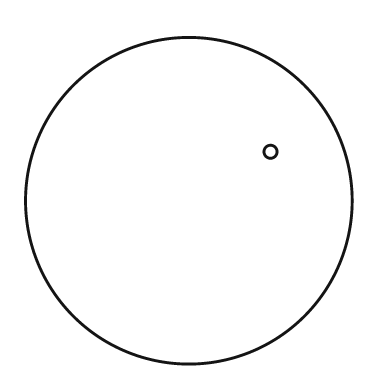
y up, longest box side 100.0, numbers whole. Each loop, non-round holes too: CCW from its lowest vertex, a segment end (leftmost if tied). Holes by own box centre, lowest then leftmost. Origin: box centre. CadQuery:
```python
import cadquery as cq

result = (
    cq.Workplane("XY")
    .moveTo(0.0, 0.0)
    .circle(50.0)
    .moveTo(25.0, 15.0)
    .circle(2.0)
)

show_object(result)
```